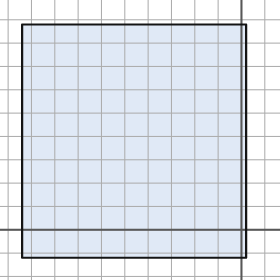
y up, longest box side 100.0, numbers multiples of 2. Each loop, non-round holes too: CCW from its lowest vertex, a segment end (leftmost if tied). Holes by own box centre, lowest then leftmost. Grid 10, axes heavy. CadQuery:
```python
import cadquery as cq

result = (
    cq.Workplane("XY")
    .moveTo(-94.0, -12.0)
    .lineTo(2.0, -12.0)
    .lineTo(2.0, 88.0)
    .lineTo(-94.0, 88.0)
    .close()
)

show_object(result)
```